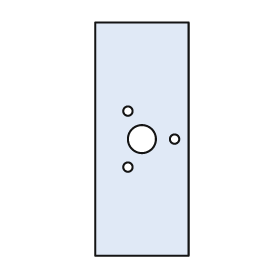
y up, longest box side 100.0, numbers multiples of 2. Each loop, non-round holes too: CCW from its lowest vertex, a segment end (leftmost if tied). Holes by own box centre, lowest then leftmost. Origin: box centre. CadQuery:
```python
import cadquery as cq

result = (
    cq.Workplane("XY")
    .moveTo(-20.0, -50.0)
    .lineTo(20.0, -50.0)
    .lineTo(20.0, 50.0)
    .lineTo(-20.0, 50.0)
    .close()
    .moveTo(-6.0, -12.0)
    .circle(2.0)
    .moveTo(0.0, 0.0)
    .circle(6.0)
    .moveTo(14.0, 0.0)
    .circle(2.0)
    .moveTo(-6.0, 12.0)
    .circle(2.0)
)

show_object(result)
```